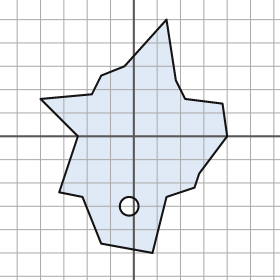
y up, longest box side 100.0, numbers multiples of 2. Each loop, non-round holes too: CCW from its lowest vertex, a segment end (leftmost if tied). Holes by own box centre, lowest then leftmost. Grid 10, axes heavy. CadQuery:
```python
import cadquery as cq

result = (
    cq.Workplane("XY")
    .moveTo(8.0, -50.0)
    .lineTo(14.0, -26.0)
    .lineTo(26.0, -22.0)
    .lineTo(28.0, -16.0)
    .lineTo(40.0, 0.0)
    .lineTo(38.0, 14.0)
    .lineTo(22.0, 16.0)
    .lineTo(18.0, 24.0)
    .lineTo(14.0, 50.0)
    .lineTo(-4.0, 30.0)
    .lineTo(-14.0, 26.0)
    .lineTo(-18.0, 18.0)
    .lineTo(-40.0, 16.0)
    .lineTo(-24.0, 0.0)
    .lineTo(-32.0, -24.0)
    .lineTo(-22.0, -26.0)
    .lineTo(-14.0, -46.0)
    .close()
    .moveTo(-2.0, -30.0)
    .circle(4.0)
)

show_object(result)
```